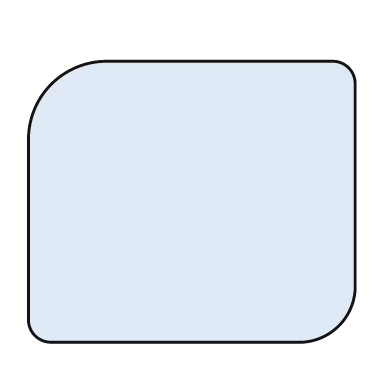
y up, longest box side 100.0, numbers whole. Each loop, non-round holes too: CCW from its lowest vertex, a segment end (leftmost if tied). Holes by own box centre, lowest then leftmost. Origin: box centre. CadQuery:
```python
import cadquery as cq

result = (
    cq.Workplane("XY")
    .moveTo(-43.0, -43.0)
    .lineTo(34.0, -43.0)
    .threePointArc((45.0, -38.0), (50.0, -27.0))
    .lineTo(50.0, 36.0)
    .threePointArc((48.0, 41.0), (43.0, 43.0))
    .lineTo(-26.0, 43.0)
    .threePointArc((-43.0, 36.0), (-50.0, 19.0))
    .lineTo(-50.0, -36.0)
    .threePointArc((-48.0, -41.0), (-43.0, -43.0))
    .close()
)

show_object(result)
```